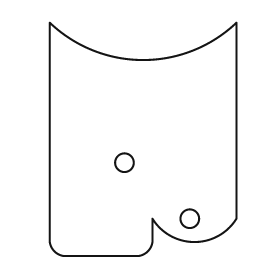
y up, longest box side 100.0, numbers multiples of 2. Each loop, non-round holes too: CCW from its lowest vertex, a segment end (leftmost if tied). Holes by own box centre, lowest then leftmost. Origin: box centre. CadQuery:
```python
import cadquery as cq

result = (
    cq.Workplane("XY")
    .moveTo(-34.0, -50.0)
    .lineTo(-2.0, -50.0)
    .threePointArc((2.0, -48.0), (4.0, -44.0))
    .lineTo(4.0, -34.0)
    .threePointArc((22.0, -44.0), (40.0, -34.0))
    .lineTo(40.0, 50.0)
    .threePointArc((0.0, 34.0), (-40.0, 50.0))
    .lineTo(-40.0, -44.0)
    .threePointArc((-38.0, -48.0), (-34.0, -50.0))
    .close()
    .moveTo(20.0, -34.0)
    .circle(4.0)
    .moveTo(-8.0, -10.0)
    .circle(4.0)
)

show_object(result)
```